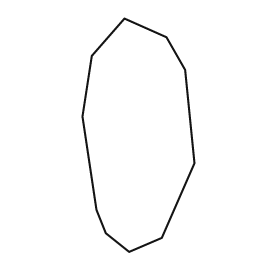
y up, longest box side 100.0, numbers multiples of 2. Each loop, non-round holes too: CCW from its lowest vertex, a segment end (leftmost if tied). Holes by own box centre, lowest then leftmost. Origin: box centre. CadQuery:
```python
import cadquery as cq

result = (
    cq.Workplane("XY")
    .moveTo(-4.0, -50.0)
    .lineTo(10.0, -44.0)
    .lineTo(24.0, -12.0)
    .lineTo(20.0, 28.0)
    .lineTo(12.0, 42.0)
    .lineTo(-6.0, 50.0)
    .lineTo(-20.0, 34.0)
    .lineTo(-24.0, 8.0)
    .lineTo(-18.0, -32.0)
    .lineTo(-14.0, -42.0)
    .close()
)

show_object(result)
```